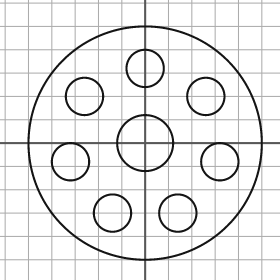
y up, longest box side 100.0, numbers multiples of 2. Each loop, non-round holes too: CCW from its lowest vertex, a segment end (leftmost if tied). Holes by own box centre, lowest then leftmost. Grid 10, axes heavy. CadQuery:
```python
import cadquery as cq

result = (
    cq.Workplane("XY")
    .moveTo(0.0, 0.0)
    .circle(50.0)
    .moveTo(-14.0, -30.0)
    .circle(8.0)
    .moveTo(14.0, -30.0)
    .circle(8.0)
    .moveTo(-32.0, -8.0)
    .circle(8.0)
    .moveTo(32.0, -8.0)
    .circle(8.0)
    .moveTo(0.0, 0.0)
    .circle(12.0)
    .moveTo(-26.0, 20.0)
    .circle(8.0)
    .moveTo(26.0, 20.0)
    .circle(8.0)
    .moveTo(0.0, 32.0)
    .circle(8.0)
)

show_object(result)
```